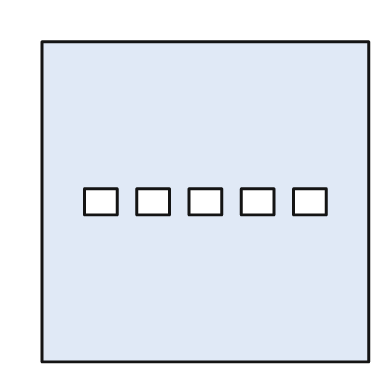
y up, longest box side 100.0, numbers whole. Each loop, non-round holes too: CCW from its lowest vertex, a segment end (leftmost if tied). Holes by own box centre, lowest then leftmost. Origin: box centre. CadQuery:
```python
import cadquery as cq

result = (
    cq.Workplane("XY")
    .moveTo(-50.0, -49.0)
    .lineTo(50.0, -49.0)
    .lineTo(50.0, 49.0)
    .lineTo(-50.0, 49.0)
    .close()
    .moveTo(-37.0, -4.0)
    .lineTo(-27.0, -4.0)
    .lineTo(-27.0, 4.0)
    .lineTo(-37.0, 4.0)
    .close()
    .moveTo(-21.0, -4.0)
    .lineTo(-11.0, -4.0)
    .lineTo(-11.0, 4.0)
    .lineTo(-21.0, 4.0)
    .close()
    .moveTo(-5.0, -4.0)
    .lineTo(5.0, -4.0)
    .lineTo(5.0, 4.0)
    .lineTo(-5.0, 4.0)
    .close()
    .moveTo(11.0, -4.0)
    .lineTo(21.0, -4.0)
    .lineTo(21.0, 4.0)
    .lineTo(11.0, 4.0)
    .close()
    .moveTo(27.0, -4.0)
    .lineTo(37.0, -4.0)
    .lineTo(37.0, 4.0)
    .lineTo(27.0, 4.0)
    .close()
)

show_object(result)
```